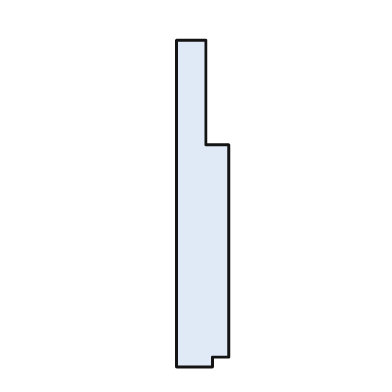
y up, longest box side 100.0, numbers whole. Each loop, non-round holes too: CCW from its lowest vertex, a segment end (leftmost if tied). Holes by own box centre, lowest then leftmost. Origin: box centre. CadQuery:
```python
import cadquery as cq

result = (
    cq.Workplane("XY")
    .moveTo(-8.0, -50.0)
    .lineTo(3.0, -50.0)
    .lineTo(3.0, -47.0)
    .lineTo(8.0, -47.0)
    .lineTo(8.0, 18.0)
    .lineTo(1.0, 18.0)
    .lineTo(1.0, 50.0)
    .lineTo(-8.0, 50.0)
    .close()
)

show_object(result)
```